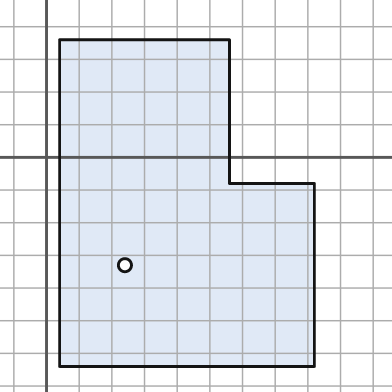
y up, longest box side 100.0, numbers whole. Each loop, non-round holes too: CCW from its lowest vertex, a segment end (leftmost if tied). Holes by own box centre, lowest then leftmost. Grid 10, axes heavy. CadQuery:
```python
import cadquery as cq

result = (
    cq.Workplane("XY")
    .moveTo(4.0, -64.0)
    .lineTo(82.0, -64.0)
    .lineTo(82.0, -8.0)
    .lineTo(56.0, -8.0)
    .lineTo(56.0, 36.0)
    .lineTo(4.0, 36.0)
    .close()
    .moveTo(24.0, -33.0)
    .circle(2.0)
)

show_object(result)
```